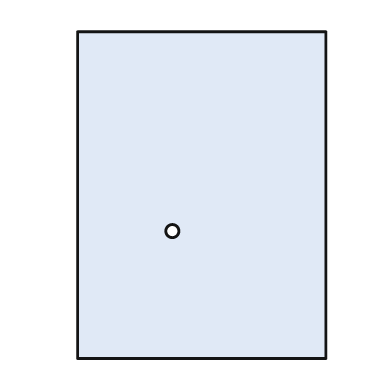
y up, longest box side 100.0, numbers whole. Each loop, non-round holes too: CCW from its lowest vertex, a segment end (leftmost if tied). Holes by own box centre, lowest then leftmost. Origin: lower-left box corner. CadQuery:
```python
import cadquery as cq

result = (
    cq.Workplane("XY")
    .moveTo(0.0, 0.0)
    .lineTo(76.0, 0.0)
    .lineTo(76.0, 100.0)
    .lineTo(0.0, 100.0)
    .close()
    .moveTo(29.0, 39.0)
    .circle(2.0)
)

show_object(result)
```